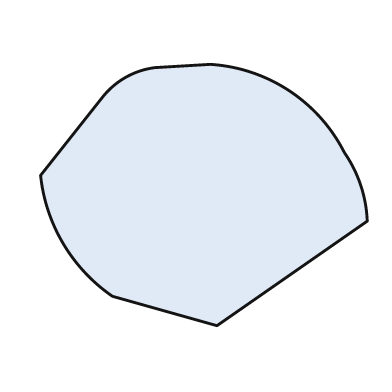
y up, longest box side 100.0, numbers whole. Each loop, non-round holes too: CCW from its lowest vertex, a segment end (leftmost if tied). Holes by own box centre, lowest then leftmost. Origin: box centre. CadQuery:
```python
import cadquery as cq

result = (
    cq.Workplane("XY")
    .moveTo(4.0, -40.0)
    .lineTo(50.0, -8.0)
    .threePointArc((48.0, 3.0), (43.0, 13.0))
    .threePointArc((26.0, 32.0), (2.0, 40.0))
    .lineTo(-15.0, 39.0)
    .threePointArc((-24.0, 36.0), (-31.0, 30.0))
    .lineTo(-50.0, 6.0)
    .threePointArc((-43.0, -15.0), (-28.0, -31.0))
    .close()
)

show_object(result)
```